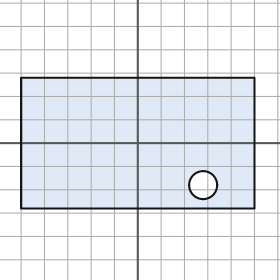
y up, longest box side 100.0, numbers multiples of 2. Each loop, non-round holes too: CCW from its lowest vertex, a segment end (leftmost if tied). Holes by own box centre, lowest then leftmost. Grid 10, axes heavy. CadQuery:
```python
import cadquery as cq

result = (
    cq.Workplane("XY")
    .moveTo(-50.0, -28.0)
    .lineTo(50.0, -28.0)
    .lineTo(50.0, 28.0)
    .lineTo(-50.0, 28.0)
    .close()
    .moveTo(28.0, -18.0)
    .circle(6.0)
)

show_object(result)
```